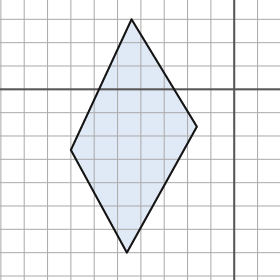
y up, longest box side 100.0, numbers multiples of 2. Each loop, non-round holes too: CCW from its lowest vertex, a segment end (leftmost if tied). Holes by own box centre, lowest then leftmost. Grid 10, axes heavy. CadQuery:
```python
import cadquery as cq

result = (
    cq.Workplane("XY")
    .moveTo(-46.0, -70.0)
    .lineTo(-16.0, -16.0)
    .lineTo(-44.0, 30.0)
    .lineTo(-70.0, -26.0)
    .close()
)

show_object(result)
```